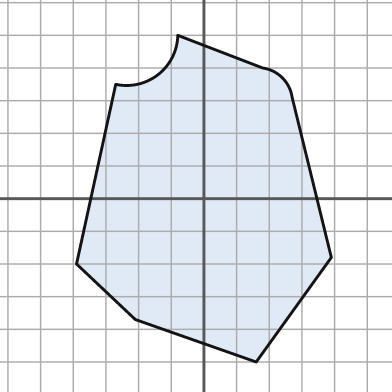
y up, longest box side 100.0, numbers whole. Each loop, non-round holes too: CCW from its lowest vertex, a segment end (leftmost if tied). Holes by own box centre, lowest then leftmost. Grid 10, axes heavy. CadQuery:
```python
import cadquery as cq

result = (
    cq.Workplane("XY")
    .moveTo(16.0, -50.0)
    .lineTo(39.0, -18.0)
    .lineTo(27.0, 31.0)
    .threePointArc((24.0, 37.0), (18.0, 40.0))
    .lineTo(-8.0, 50.0)
    .threePointArc((-14.0, 38.0), (-27.0, 35.0))
    .lineTo(-39.0, -20.0)
    .lineTo(-21.0, -37.0)
    .close()
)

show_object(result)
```